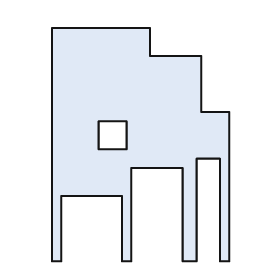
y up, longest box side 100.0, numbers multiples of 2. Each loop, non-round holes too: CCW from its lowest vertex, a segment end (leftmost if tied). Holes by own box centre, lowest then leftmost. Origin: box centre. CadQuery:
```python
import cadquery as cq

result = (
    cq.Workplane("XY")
    .moveTo(-38.0, -50.0)
    .lineTo(-34.0, -50.0)
    .lineTo(-34.0, -22.0)
    .lineTo(-8.0, -22.0)
    .lineTo(-8.0, -50.0)
    .lineTo(-4.0, -50.0)
    .lineTo(-4.0, -10.0)
    .lineTo(18.0, -10.0)
    .lineTo(18.0, -50.0)
    .lineTo(24.0, -50.0)
    .lineTo(24.0, -6.0)
    .lineTo(34.0, -6.0)
    .lineTo(34.0, -50.0)
    .lineTo(38.0, -50.0)
    .lineTo(38.0, 14.0)
    .lineTo(26.0, 14.0)
    .lineTo(26.0, 38.0)
    .lineTo(4.0, 38.0)
    .lineTo(4.0, 50.0)
    .lineTo(-38.0, 50.0)
    .close()
    .moveTo(-18.0, -2.0)
    .lineTo(-6.0, -2.0)
    .lineTo(-6.0, 10.0)
    .lineTo(-18.0, 10.0)
    .close()
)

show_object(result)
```